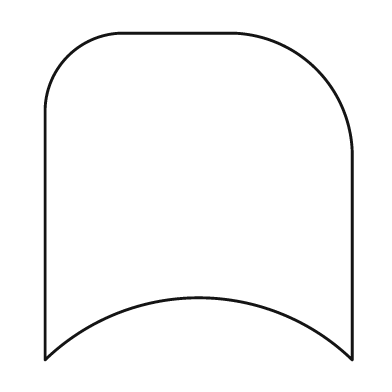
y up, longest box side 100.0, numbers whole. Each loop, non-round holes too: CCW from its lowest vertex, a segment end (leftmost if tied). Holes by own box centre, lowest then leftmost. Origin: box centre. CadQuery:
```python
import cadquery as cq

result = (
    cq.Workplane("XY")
    .moveTo(-47.0, -50.0)
    .threePointArc((0.0, -31.0), (47.0, -50.0))
    .lineTo(47.0, 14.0)
    .threePointArc((36.0, 39.0), (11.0, 50.0))
    .lineTo(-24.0, 50.0)
    .threePointArc((-40.0, 43.0), (-47.0, 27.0))
    .close()
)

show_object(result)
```